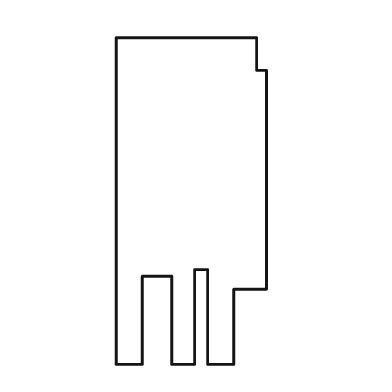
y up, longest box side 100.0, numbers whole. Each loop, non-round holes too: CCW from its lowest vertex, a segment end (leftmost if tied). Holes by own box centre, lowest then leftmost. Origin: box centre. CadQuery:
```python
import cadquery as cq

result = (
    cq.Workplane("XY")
    .moveTo(-23.0, -50.0)
    .lineTo(-15.0, -50.0)
    .lineTo(-15.0, -23.0)
    .lineTo(-6.0, -23.0)
    .lineTo(-6.0, -50.0)
    .lineTo(1.0, -50.0)
    .lineTo(1.0, -21.0)
    .lineTo(5.0, -21.0)
    .lineTo(5.0, -50.0)
    .lineTo(13.0, -50.0)
    .lineTo(13.0, -27.0)
    .lineTo(23.0, -27.0)
    .lineTo(23.0, 40.0)
    .lineTo(20.0, 40.0)
    .lineTo(20.0, 50.0)
    .lineTo(-23.0, 50.0)
    .close()
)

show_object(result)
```